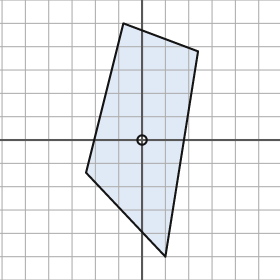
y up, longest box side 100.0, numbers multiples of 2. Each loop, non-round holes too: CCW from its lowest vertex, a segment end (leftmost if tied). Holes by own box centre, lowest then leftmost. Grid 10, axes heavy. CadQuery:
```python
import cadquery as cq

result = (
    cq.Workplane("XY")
    .moveTo(10.0, -50.0)
    .lineTo(24.0, 38.0)
    .lineTo(-8.0, 50.0)
    .lineTo(-24.0, -14.0)
    .close()
    .moveTo(0.0, 0.0)
    .circle(2.0)
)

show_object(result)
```